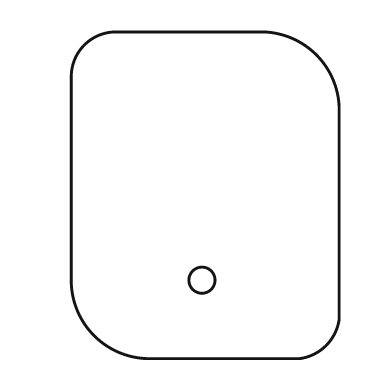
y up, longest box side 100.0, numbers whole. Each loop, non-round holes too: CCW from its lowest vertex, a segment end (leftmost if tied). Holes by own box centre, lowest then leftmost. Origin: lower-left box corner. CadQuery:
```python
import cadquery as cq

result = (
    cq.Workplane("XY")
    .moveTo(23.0, 0.0)
    .lineTo(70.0, 0.0)
    .threePointArc((78.0, 4.0), (82.0, 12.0))
    .lineTo(82.0, 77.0)
    .threePointArc((75.0, 93.0), (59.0, 100.0))
    .lineTo(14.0, 100.0)
    .threePointArc((4.0, 96.0), (0.0, 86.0))
    .lineTo(0.0, 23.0)
    .threePointArc((7.0, 7.0), (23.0, 0.0))
    .close()
    .moveTo(40.0, 24.0)
    .circle(4.0)
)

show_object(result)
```